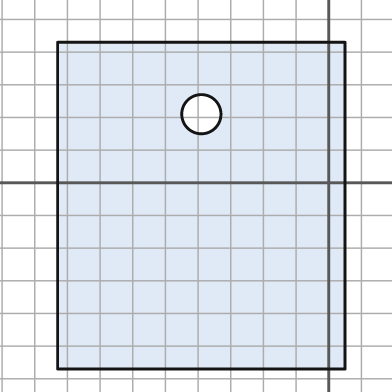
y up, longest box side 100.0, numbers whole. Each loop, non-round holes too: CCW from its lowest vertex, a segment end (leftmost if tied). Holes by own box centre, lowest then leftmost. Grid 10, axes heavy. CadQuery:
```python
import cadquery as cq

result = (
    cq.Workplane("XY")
    .moveTo(-83.0, -57.0)
    .lineTo(5.0, -57.0)
    .lineTo(5.0, 43.0)
    .lineTo(-83.0, 43.0)
    .close()
    .moveTo(-39.0, 21.0)
    .circle(6.0)
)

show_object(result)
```